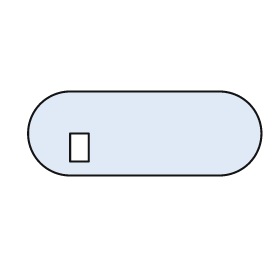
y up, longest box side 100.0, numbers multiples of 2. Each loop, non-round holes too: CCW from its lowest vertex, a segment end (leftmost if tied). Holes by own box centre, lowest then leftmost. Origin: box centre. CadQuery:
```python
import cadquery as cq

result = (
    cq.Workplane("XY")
    .moveTo(-32.0, -18.0)
    .lineTo(32.0, -18.0)
    .threePointArc((50.0, 0.0), (32.0, 18.0))
    .lineTo(-32.0, 18.0)
    .threePointArc((-50.0, 0.0), (-32.0, -18.0))
    .close()
    .moveTo(-32.0, -12.0)
    .lineTo(-24.0, -12.0)
    .lineTo(-24.0, 0.0)
    .lineTo(-32.0, 0.0)
    .close()
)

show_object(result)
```